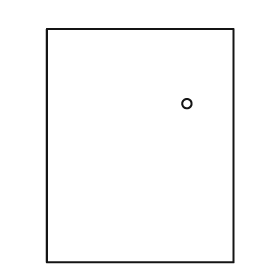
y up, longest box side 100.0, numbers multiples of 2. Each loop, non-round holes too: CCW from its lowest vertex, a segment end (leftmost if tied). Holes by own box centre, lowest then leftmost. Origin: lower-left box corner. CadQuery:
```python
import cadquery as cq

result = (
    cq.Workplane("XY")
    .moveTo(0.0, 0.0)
    .lineTo(80.0, 0.0)
    .lineTo(80.0, 100.0)
    .lineTo(0.0, 100.0)
    .close()
    .moveTo(60.0, 68.0)
    .circle(2.0)
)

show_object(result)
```